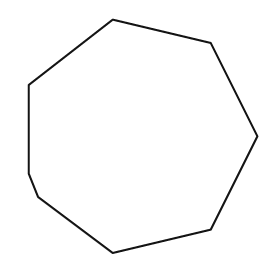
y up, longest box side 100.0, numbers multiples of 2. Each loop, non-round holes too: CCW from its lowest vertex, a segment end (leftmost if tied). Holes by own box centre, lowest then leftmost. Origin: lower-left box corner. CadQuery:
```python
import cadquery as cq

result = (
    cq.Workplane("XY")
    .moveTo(36.0, 0.0)
    .lineTo(78.0, 10.0)
    .lineTo(98.0, 50.0)
    .lineTo(78.0, 90.0)
    .lineTo(36.0, 100.0)
    .lineTo(0.0, 72.0)
    .lineTo(0.0, 34.0)
    .lineTo(4.0, 24.0)
    .close()
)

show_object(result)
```